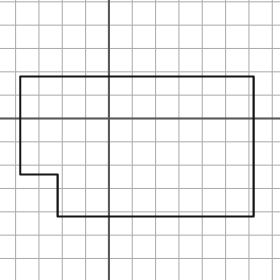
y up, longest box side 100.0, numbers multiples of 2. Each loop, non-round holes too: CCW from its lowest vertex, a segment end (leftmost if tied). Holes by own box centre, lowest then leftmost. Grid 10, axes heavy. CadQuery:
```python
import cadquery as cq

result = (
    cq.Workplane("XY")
    .moveTo(-22.0, -42.0)
    .lineTo(62.0, -42.0)
    .lineTo(62.0, 18.0)
    .lineTo(-38.0, 18.0)
    .lineTo(-38.0, -24.0)
    .lineTo(-22.0, -24.0)
    .close()
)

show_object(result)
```